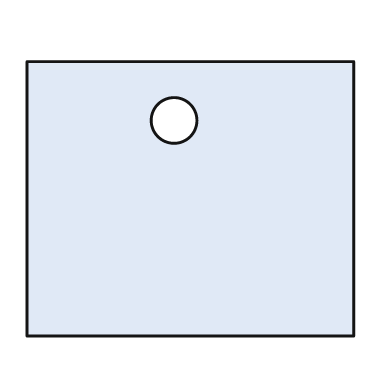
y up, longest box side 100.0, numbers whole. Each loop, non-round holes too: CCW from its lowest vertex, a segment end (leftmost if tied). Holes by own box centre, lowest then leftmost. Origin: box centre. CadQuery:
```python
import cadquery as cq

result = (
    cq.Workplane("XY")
    .moveTo(-50.0, -42.0)
    .lineTo(50.0, -42.0)
    .lineTo(50.0, 42.0)
    .lineTo(-50.0, 42.0)
    .close()
    .moveTo(-5.0, 24.0)
    .circle(7.0)
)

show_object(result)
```